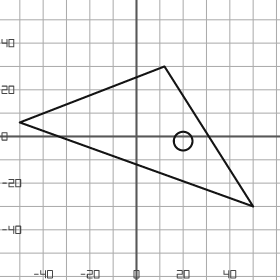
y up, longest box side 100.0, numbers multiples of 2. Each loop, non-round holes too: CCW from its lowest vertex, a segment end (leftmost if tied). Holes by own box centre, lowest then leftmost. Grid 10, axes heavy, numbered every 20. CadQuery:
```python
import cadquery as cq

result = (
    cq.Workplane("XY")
    .moveTo(50.0, -30.0)
    .lineTo(12.0, 30.0)
    .lineTo(-50.0, 6.0)
    .close()
    .moveTo(20.0, -2.0)
    .circle(4.0)
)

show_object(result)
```